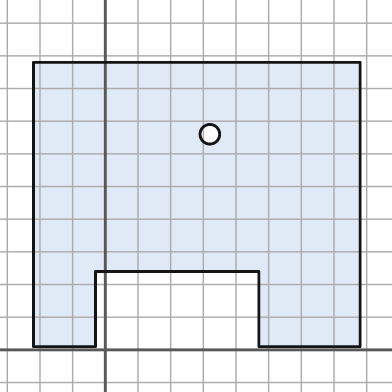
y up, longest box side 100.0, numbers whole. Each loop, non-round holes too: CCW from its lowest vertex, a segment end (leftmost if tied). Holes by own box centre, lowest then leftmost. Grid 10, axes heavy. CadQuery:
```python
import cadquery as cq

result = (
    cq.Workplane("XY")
    .moveTo(-22.0, 1.0)
    .lineTo(-3.0, 1.0)
    .lineTo(-3.0, 24.0)
    .lineTo(47.0, 24.0)
    .lineTo(47.0, 1.0)
    .lineTo(78.0, 1.0)
    .lineTo(78.0, 88.0)
    .lineTo(-22.0, 88.0)
    .close()
    .moveTo(32.0, 66.0)
    .circle(3.0)
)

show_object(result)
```